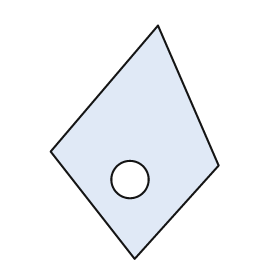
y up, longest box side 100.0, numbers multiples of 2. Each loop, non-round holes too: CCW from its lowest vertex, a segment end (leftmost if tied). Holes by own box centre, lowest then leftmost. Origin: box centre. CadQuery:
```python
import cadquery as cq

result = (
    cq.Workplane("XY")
    .moveTo(0.0, -50.0)
    .lineTo(36.0, -10.0)
    .lineTo(10.0, 50.0)
    .lineTo(-36.0, -4.0)
    .close()
    .moveTo(-2.0, -16.0)
    .circle(8.0)
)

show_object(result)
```